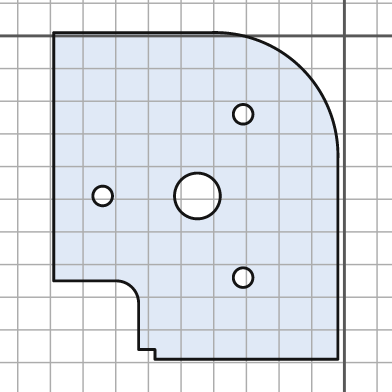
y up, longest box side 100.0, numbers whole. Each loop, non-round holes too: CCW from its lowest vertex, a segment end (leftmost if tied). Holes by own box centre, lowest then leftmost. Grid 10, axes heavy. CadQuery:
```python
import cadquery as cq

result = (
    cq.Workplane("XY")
    .moveTo(-58.0, -99.0)
    .lineTo(-2.0, -99.0)
    .lineTo(-2.0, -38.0)
    .threePointArc((-13.0, -10.0), (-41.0, 1.0))
    .lineTo(-89.0, 1.0)
    .lineTo(-89.0, -75.0)
    .lineTo(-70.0, -75.0)
    .threePointArc((-65.0, -77.0), (-63.0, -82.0))
    .lineTo(-63.0, -96.0)
    .lineTo(-58.0, -96.0)
    .close()
    .moveTo(-31.0, -74.0)
    .circle(3.0)
    .moveTo(-74.0, -49.0)
    .circle(3.0)
    .moveTo(-45.0, -49.0)
    .circle(7.0)
    .moveTo(-31.0, -24.0)
    .circle(3.0)
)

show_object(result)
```